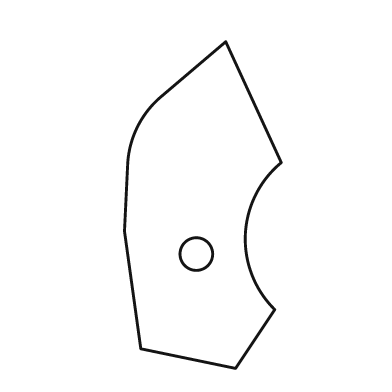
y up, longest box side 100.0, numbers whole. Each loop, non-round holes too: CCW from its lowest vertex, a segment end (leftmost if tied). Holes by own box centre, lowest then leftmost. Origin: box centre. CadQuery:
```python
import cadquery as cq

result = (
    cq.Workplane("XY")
    .moveTo(10.0, -50.0)
    .lineTo(22.0, -32.0)
    .threePointArc((13.0, -9.0), (24.0, 13.0))
    .lineTo(7.0, 50.0)
    .lineTo(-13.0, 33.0)
    .threePointArc((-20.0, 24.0), (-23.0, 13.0))
    .lineTo(-24.0, -8.0)
    .lineTo(-19.0, -44.0)
    .close()
    .moveTo(-2.0, -15.0)
    .circle(5.0)
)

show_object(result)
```